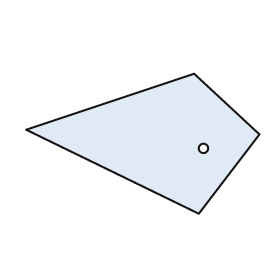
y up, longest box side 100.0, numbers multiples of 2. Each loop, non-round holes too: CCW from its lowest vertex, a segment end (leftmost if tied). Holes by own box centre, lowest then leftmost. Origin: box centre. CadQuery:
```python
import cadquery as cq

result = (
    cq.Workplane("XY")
    .moveTo(24.0, -30.0)
    .lineTo(50.0, 4.0)
    .lineTo(22.0, 30.0)
    .lineTo(-50.0, 6.0)
    .close()
    .moveTo(26.0, -2.0)
    .circle(2.0)
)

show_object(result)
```